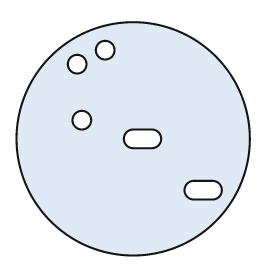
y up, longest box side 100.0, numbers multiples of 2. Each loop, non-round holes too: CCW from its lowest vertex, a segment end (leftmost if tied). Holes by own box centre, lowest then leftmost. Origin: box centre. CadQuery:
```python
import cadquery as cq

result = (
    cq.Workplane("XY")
    .moveTo(0.0, 0.0)
    .circle(50.0)
    .moveTo(26.0, -26.0)
    .lineTo(34.0, -26.0)
    .threePointArc((38.0, -22.0), (34.0, -18.0))
    .lineTo(26.0, -18.0)
    .threePointArc((22.0, -22.0), (26.0, -26.0))
    .close()
    .moveTo(0.0, -4.0)
    .lineTo(8.0, -4.0)
    .threePointArc((12.0, 0.0), (8.0, 4.0))
    .lineTo(0.0, 4.0)
    .threePointArc((-4.0, 0.0), (0.0, -4.0))
    .close()
    .moveTo(-22.0, 8.0)
    .circle(4.0)
    .moveTo(-24.0, 32.0)
    .circle(4.0)
    .moveTo(-12.0, 38.0)
    .circle(4.0)
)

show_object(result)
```